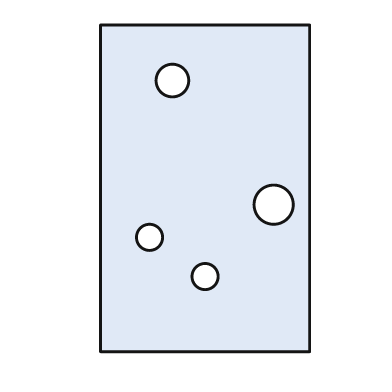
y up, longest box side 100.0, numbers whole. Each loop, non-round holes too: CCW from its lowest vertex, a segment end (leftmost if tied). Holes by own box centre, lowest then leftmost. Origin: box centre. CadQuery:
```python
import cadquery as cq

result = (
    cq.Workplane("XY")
    .moveTo(-32.0, -50.0)
    .lineTo(32.0, -50.0)
    .lineTo(32.0, 50.0)
    .lineTo(-32.0, 50.0)
    .close()
    .moveTo(0.0, -27.0)
    .circle(4.0)
    .moveTo(-17.0, -15.0)
    .circle(4.0)
    .moveTo(21.0, -5.0)
    .circle(6.0)
    .moveTo(-10.0, 33.0)
    .circle(5.0)
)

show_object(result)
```